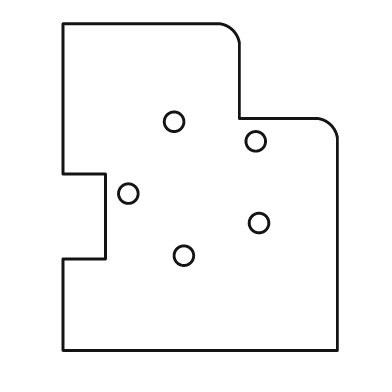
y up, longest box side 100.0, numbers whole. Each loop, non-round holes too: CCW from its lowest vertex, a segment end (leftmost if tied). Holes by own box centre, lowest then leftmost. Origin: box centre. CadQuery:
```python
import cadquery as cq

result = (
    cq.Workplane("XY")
    .moveTo(-42.0, -50.0)
    .lineTo(42.0, -50.0)
    .lineTo(42.0, 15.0)
    .threePointArc((40.0, 19.0), (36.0, 21.0))
    .lineTo(12.0, 21.0)
    .lineTo(12.0, 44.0)
    .threePointArc((10.0, 48.0), (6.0, 50.0))
    .lineTo(-42.0, 50.0)
    .lineTo(-42.0, 4.0)
    .lineTo(-29.0, 4.0)
    .lineTo(-29.0, -22.0)
    .lineTo(-42.0, -22.0)
    .close()
    .moveTo(-5.0, -21.0)
    .circle(3.0)
    .moveTo(18.0, -11.0)
    .circle(3.0)
    .moveTo(-22.0, -2.0)
    .circle(3.0)
    .moveTo(17.0, 14.0)
    .circle(3.0)
    .moveTo(-8.0, 20.0)
    .circle(3.0)
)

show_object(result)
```